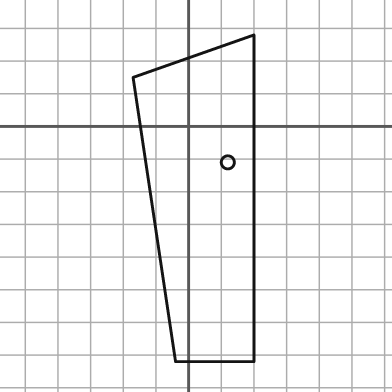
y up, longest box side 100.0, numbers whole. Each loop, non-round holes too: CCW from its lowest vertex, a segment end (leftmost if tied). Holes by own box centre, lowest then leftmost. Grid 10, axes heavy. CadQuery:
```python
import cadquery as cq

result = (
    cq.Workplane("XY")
    .moveTo(-4.0, -72.0)
    .lineTo(20.0, -72.0)
    .lineTo(20.0, 28.0)
    .lineTo(-17.0, 15.0)
    .close()
    .moveTo(12.0, -11.0)
    .circle(2.0)
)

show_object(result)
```